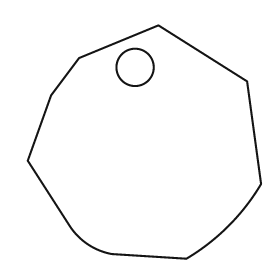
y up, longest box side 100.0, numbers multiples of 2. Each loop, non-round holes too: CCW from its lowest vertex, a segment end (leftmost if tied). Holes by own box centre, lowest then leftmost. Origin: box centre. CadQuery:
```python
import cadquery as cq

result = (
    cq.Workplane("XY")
    .moveTo(18.0, -50.0)
    .threePointArc((36.0, -36.0), (50.0, -18.0))
    .lineTo(44.0, 26.0)
    .lineTo(6.0, 50.0)
    .lineTo(-28.0, 36.0)
    .lineTo(-40.0, 20.0)
    .lineTo(-50.0, -8.0)
    .lineTo(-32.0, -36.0)
    .threePointArc((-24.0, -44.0), (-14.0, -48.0))
    .close()
    .moveTo(-4.0, 32.0)
    .circle(8.0)
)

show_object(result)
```